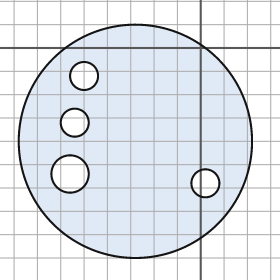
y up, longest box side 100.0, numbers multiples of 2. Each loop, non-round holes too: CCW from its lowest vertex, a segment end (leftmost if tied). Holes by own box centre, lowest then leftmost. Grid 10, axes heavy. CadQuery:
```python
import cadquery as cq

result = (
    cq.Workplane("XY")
    .moveTo(-28.0, -40.0)
    .circle(50.0)
    .moveTo(2.0, -58.0)
    .circle(6.0)
    .moveTo(-56.0, -54.0)
    .circle(8.0)
    .moveTo(-54.0, -32.0)
    .circle(6.0)
    .moveTo(-50.0, -12.0)
    .circle(6.0)
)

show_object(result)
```